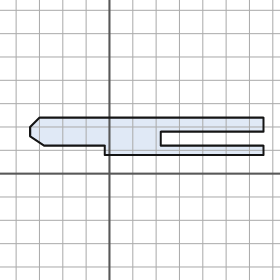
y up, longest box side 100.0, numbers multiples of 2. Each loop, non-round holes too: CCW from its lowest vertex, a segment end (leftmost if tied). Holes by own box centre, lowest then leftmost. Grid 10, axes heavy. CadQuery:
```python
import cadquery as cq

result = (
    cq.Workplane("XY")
    .moveTo(-2.0, 8.0)
    .lineTo(66.0, 8.0)
    .lineTo(66.0, 12.0)
    .lineTo(22.0, 12.0)
    .lineTo(22.0, 18.0)
    .lineTo(66.0, 18.0)
    .lineTo(66.0, 24.0)
    .lineTo(-30.0, 24.0)
    .lineTo(-34.0, 20.0)
    .lineTo(-34.0, 16.0)
    .lineTo(-28.0, 12.0)
    .lineTo(-2.0, 12.0)
    .close()
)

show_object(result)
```